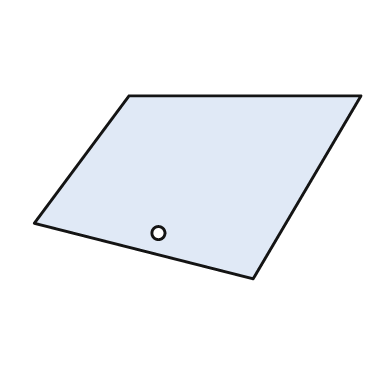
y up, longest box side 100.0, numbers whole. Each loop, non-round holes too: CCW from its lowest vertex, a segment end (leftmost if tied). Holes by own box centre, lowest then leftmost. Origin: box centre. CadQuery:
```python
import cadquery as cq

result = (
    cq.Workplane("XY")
    .moveTo(17.0, -28.0)
    .lineTo(50.0, 28.0)
    .lineTo(-21.0, 28.0)
    .lineTo(-50.0, -11.0)
    .close()
    .moveTo(-12.0, -14.0)
    .circle(2.0)
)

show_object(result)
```